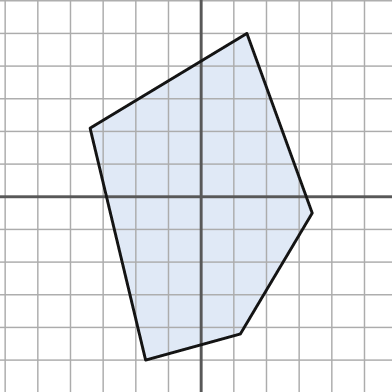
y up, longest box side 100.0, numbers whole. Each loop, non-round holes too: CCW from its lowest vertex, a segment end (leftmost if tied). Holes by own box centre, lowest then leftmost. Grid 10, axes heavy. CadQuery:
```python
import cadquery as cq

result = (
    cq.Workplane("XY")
    .moveTo(-17.0, -50.0)
    .lineTo(12.0, -42.0)
    .lineTo(34.0, -5.0)
    .lineTo(14.0, 50.0)
    .lineTo(-34.0, 21.0)
    .close()
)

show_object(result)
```